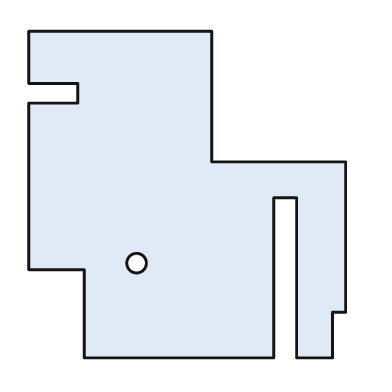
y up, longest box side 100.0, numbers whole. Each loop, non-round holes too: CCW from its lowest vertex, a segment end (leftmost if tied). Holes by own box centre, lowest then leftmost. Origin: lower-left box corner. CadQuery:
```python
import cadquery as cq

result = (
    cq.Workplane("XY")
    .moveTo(17.0, 0.0)
    .lineTo(75.0, 0.0)
    .lineTo(75.0, 49.0)
    .lineTo(82.0, 49.0)
    .lineTo(82.0, 0.0)
    .lineTo(93.0, 0.0)
    .lineTo(93.0, 14.0)
    .lineTo(97.0, 14.0)
    .lineTo(97.0, 60.0)
    .lineTo(56.0, 60.0)
    .lineTo(56.0, 100.0)
    .lineTo(0.0, 100.0)
    .lineTo(0.0, 84.0)
    .lineTo(15.0, 84.0)
    .lineTo(15.0, 78.0)
    .lineTo(0.0, 78.0)
    .lineTo(0.0, 27.0)
    .lineTo(17.0, 27.0)
    .close()
    .moveTo(33.0, 29.0)
    .circle(3.0)
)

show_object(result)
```